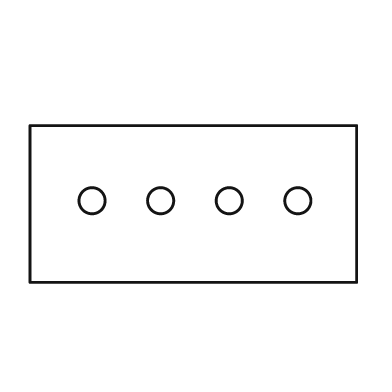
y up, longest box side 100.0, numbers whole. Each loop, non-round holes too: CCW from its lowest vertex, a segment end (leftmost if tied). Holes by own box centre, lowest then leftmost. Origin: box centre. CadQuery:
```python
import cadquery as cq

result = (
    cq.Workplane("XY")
    .moveTo(-50.0, -24.0)
    .lineTo(50.0, -24.0)
    .lineTo(50.0, 24.0)
    .lineTo(-50.0, 24.0)
    .close()
    .moveTo(-31.0, 1.0)
    .circle(4.0)
    .moveTo(-10.0, 1.0)
    .circle(4.0)
    .moveTo(11.0, 1.0)
    .circle(4.0)
    .moveTo(32.0, 1.0)
    .circle(4.0)
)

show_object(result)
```